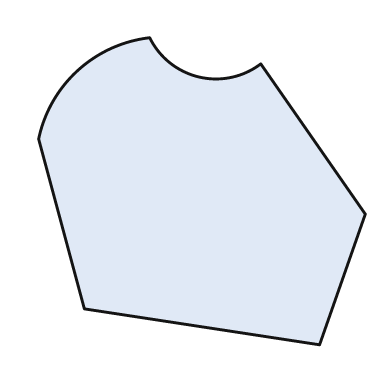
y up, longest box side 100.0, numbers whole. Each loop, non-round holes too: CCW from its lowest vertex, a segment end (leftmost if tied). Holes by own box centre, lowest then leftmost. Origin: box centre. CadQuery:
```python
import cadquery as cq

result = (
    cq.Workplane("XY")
    .moveTo(36.0, -47.0)
    .lineTo(50.0, -7.0)
    .lineTo(18.0, 39.0)
    .threePointArc((-1.0, 35.0), (-16.0, 47.0))
    .threePointArc((-38.0, 37.0), (-50.0, 16.0))
    .lineTo(-36.0, -36.0)
    .close()
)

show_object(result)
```